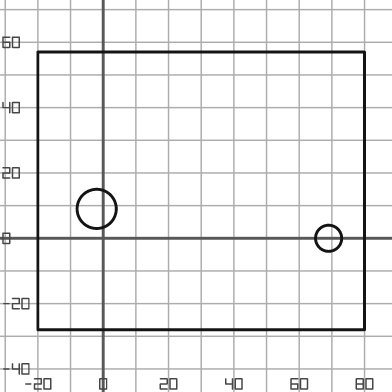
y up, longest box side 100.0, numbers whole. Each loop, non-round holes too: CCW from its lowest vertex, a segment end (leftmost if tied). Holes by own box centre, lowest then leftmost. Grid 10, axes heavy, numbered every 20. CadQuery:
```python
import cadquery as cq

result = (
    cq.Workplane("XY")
    .moveTo(-20.0, -28.0)
    .lineTo(80.0, -28.0)
    .lineTo(80.0, 57.0)
    .lineTo(-20.0, 57.0)
    .close()
    .moveTo(69.0, 0.0)
    .circle(4.0)
    .moveTo(-2.0, 9.0)
    .circle(6.0)
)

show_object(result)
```